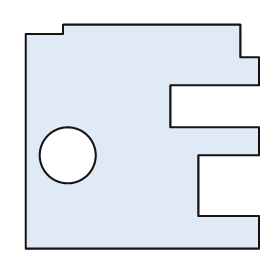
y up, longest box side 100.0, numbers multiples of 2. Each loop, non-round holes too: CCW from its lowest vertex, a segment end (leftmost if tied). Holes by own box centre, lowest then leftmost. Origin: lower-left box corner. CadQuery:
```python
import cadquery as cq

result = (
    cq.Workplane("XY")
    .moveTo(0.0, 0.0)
    .lineTo(100.0, 0.0)
    .lineTo(100.0, 14.0)
    .lineTo(74.0, 14.0)
    .lineTo(74.0, 40.0)
    .lineTo(100.0, 40.0)
    .lineTo(100.0, 52.0)
    .lineTo(62.0, 52.0)
    .lineTo(62.0, 70.0)
    .lineTo(100.0, 70.0)
    .lineTo(100.0, 82.0)
    .lineTo(92.0, 82.0)
    .lineTo(92.0, 96.0)
    .lineTo(16.0, 96.0)
    .lineTo(16.0, 92.0)
    .lineTo(0.0, 92.0)
    .close()
    .moveTo(18.0, 40.0)
    .circle(12.0)
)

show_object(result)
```